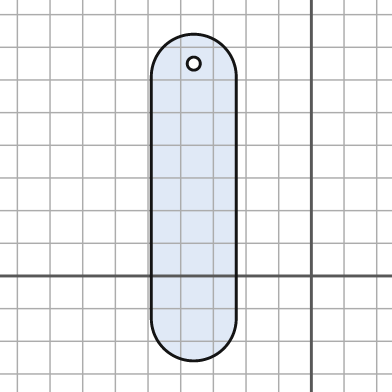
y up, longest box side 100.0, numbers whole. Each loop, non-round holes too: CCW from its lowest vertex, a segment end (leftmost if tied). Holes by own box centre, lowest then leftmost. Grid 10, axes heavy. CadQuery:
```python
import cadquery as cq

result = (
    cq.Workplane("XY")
    .moveTo(-49.0, -13.0)
    .threePointArc((-36.0, -26.0), (-23.0, -13.0))
    .lineTo(-23.0, 61.0)
    .threePointArc((-36.0, 74.0), (-49.0, 61.0))
    .close()
    .moveTo(-36.0, 65.0)
    .circle(2.0)
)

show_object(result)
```